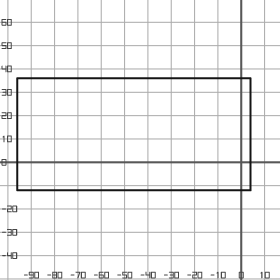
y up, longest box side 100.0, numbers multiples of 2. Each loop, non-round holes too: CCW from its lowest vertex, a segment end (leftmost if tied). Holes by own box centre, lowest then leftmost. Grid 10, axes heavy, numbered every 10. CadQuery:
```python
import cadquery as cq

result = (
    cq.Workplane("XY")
    .moveTo(-96.0, -12.0)
    .lineTo(4.0, -12.0)
    .lineTo(4.0, 36.0)
    .lineTo(-96.0, 36.0)
    .close()
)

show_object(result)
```